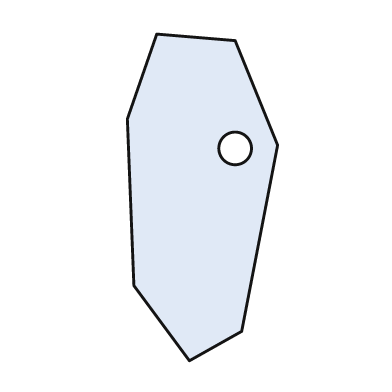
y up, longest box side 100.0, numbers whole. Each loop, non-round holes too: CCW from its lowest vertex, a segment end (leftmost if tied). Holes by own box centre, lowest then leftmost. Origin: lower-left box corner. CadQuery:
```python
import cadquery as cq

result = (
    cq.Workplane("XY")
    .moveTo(19.0, 0.0)
    .lineTo(35.0, 9.0)
    .lineTo(46.0, 66.0)
    .lineTo(33.0, 98.0)
    .lineTo(9.0, 100.0)
    .lineTo(0.0, 74.0)
    .lineTo(2.0, 23.0)
    .close()
    .moveTo(33.0, 65.0)
    .circle(5.0)
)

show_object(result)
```